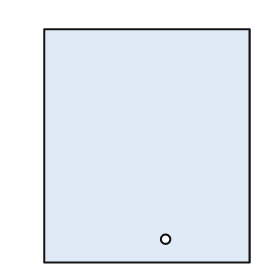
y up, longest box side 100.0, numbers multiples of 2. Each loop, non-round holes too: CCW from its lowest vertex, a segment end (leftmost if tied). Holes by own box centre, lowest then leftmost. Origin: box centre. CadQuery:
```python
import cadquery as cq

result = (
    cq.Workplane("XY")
    .moveTo(-44.0, -50.0)
    .lineTo(44.0, -50.0)
    .lineTo(44.0, 50.0)
    .lineTo(-44.0, 50.0)
    .close()
    .moveTo(8.0, -40.0)
    .circle(2.0)
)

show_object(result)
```